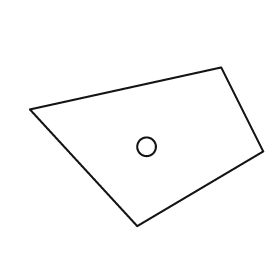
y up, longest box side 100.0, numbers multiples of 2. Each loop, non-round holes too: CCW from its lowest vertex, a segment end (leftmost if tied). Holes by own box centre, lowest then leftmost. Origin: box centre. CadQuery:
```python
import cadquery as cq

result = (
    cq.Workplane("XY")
    .moveTo(-4.0, -34.0)
    .lineTo(50.0, -2.0)
    .lineTo(32.0, 34.0)
    .lineTo(-50.0, 16.0)
    .close()
    .moveTo(0.0, 0.0)
    .circle(4.0)
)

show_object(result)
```